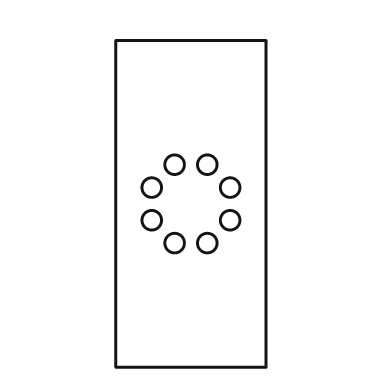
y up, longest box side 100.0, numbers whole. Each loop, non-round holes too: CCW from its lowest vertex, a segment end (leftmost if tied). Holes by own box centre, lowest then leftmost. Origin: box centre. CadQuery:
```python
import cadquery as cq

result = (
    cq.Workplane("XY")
    .moveTo(-23.0, -50.0)
    .lineTo(23.0, -50.0)
    .lineTo(23.0, 50.0)
    .lineTo(-23.0, 50.0)
    .close()
    .moveTo(-5.0, -12.0)
    .circle(3.0)
    .moveTo(5.0, -12.0)
    .circle(3.0)
    .moveTo(-12.0, -5.0)
    .circle(3.0)
    .moveTo(12.0, -5.0)
    .circle(3.0)
    .moveTo(-12.0, 5.0)
    .circle(3.0)
    .moveTo(12.0, 5.0)
    .circle(3.0)
    .moveTo(-5.0, 12.0)
    .circle(3.0)
    .moveTo(5.0, 12.0)
    .circle(3.0)
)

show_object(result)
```